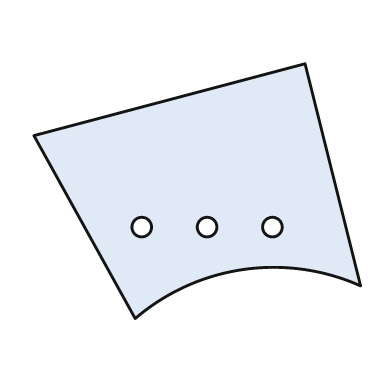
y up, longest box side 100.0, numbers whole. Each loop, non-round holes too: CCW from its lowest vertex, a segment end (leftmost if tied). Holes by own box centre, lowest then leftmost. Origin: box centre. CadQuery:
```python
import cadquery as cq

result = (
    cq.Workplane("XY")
    .moveTo(-19.0, -39.0)
    .threePointArc((14.0, -24.0), (50.0, -29.0))
    .lineTo(33.0, 39.0)
    .lineTo(-50.0, 17.0)
    .close()
    .moveTo(-17.0, -11.0)
    .circle(3.0)
    .moveTo(3.0, -11.0)
    .circle(3.0)
    .moveTo(23.0, -11.0)
    .circle(3.0)
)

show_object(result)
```